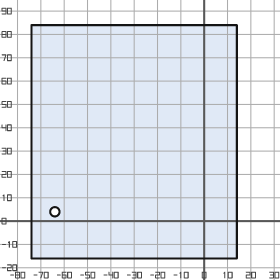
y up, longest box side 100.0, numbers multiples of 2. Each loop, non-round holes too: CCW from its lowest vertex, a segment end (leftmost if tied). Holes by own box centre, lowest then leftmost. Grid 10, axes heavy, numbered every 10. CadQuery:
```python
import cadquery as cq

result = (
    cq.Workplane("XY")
    .moveTo(-74.0, -16.0)
    .lineTo(14.0, -16.0)
    .lineTo(14.0, 84.0)
    .lineTo(-74.0, 84.0)
    .close()
    .moveTo(-64.0, 4.0)
    .circle(2.0)
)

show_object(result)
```